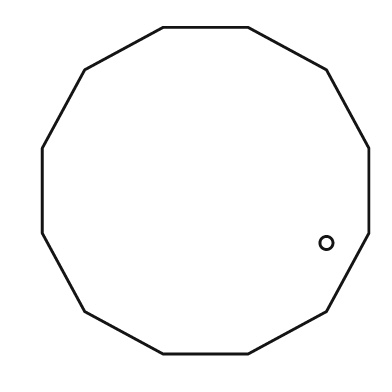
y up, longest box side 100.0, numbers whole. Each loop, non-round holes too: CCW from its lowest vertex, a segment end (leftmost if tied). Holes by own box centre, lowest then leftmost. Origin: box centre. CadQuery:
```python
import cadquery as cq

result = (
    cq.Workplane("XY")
    .moveTo(-13.0, -50.0)
    .lineTo(13.0, -50.0)
    .lineTo(37.0, -37.0)
    .lineTo(50.0, -13.0)
    .lineTo(50.0, 13.0)
    .lineTo(37.0, 37.0)
    .lineTo(13.0, 50.0)
    .lineTo(-13.0, 50.0)
    .lineTo(-37.0, 37.0)
    .lineTo(-50.0, 13.0)
    .lineTo(-50.0, -13.0)
    .lineTo(-37.0, -37.0)
    .close()
    .moveTo(37.0, -16.0)
    .circle(2.0)
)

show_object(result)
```